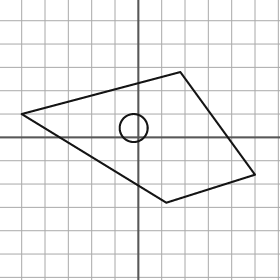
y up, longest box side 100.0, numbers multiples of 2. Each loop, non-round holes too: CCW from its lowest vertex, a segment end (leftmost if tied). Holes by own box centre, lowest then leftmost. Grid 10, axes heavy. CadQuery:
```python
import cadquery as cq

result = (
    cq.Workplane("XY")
    .moveTo(12.0, -28.0)
    .lineTo(50.0, -16.0)
    .lineTo(18.0, 28.0)
    .lineTo(-50.0, 10.0)
    .close()
    .moveTo(-2.0, 4.0)
    .circle(6.0)
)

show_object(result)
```